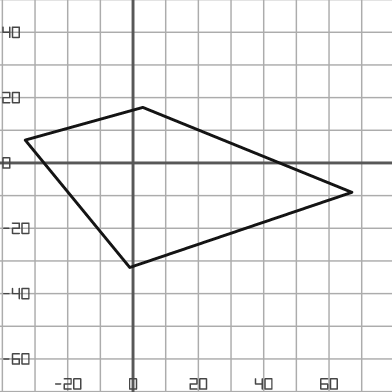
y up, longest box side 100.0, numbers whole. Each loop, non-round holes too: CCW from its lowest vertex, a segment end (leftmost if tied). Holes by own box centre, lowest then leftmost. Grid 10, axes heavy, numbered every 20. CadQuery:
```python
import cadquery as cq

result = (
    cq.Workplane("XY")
    .moveTo(-1.0, -32.0)
    .lineTo(67.0, -9.0)
    .lineTo(3.0, 17.0)
    .lineTo(-33.0, 7.0)
    .close()
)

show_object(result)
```